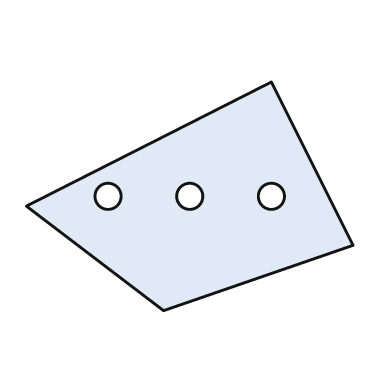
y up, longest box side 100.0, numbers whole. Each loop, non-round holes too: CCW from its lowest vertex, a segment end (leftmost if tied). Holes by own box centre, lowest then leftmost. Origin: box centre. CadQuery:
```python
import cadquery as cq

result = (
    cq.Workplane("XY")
    .moveTo(-8.0, -35.0)
    .lineTo(50.0, -15.0)
    .lineTo(25.0, 35.0)
    .lineTo(-50.0, -3.0)
    .close()
    .moveTo(-25.0, 0.0)
    .circle(4.0)
    .moveTo(0.0, 0.0)
    .circle(4.0)
    .moveTo(25.0, 0.0)
    .circle(4.0)
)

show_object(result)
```